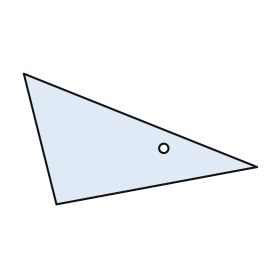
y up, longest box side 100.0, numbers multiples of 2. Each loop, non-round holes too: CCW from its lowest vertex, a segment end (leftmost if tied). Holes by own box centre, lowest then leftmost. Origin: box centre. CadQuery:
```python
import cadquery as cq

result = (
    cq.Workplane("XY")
    .moveTo(-36.0, -28.0)
    .lineTo(50.0, -12.0)
    .lineTo(-50.0, 28.0)
    .close()
    .moveTo(10.0, -4.0)
    .circle(2.0)
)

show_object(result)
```